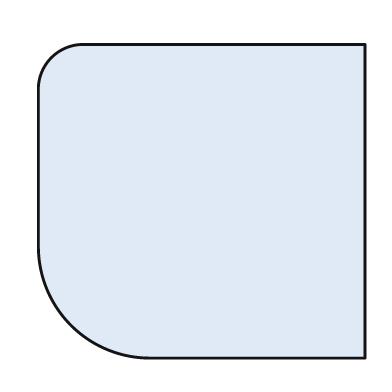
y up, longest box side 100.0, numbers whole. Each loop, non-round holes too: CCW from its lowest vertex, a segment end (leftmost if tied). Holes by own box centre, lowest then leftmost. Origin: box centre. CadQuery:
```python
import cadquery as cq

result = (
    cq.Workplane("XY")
    .moveTo(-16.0, -48.0)
    .lineTo(50.0, -48.0)
    .lineTo(50.0, 48.0)
    .lineTo(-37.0, 48.0)
    .threePointArc((-46.0, 44.0), (-50.0, 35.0))
    .lineTo(-50.0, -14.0)
    .threePointArc((-40.0, -38.0), (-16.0, -48.0))
    .close()
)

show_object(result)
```